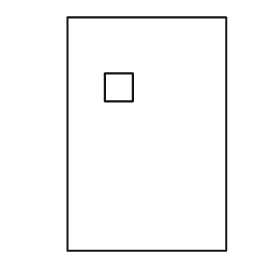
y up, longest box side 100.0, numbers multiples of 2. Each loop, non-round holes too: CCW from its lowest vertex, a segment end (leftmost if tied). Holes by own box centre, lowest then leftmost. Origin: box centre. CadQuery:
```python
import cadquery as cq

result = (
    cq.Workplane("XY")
    .moveTo(-34.0, -50.0)
    .lineTo(34.0, -50.0)
    .lineTo(34.0, 50.0)
    .lineTo(-34.0, 50.0)
    .close()
    .moveTo(-18.0, 14.0)
    .lineTo(-6.0, 14.0)
    .lineTo(-6.0, 26.0)
    .lineTo(-18.0, 26.0)
    .close()
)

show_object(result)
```